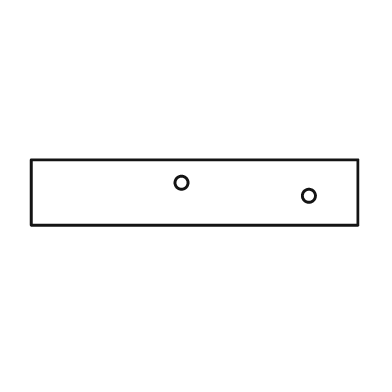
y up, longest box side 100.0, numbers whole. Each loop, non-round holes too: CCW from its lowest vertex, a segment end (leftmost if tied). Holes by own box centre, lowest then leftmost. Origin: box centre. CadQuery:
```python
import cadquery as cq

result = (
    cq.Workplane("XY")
    .moveTo(-50.0, -10.0)
    .lineTo(50.0, -10.0)
    .lineTo(50.0, 10.0)
    .lineTo(-50.0, 10.0)
    .close()
    .moveTo(35.0, -1.0)
    .circle(2.0)
    .moveTo(-4.0, 3.0)
    .circle(2.0)
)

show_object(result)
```